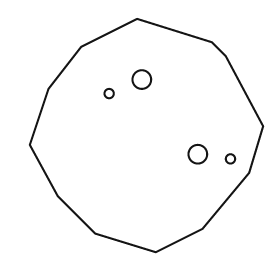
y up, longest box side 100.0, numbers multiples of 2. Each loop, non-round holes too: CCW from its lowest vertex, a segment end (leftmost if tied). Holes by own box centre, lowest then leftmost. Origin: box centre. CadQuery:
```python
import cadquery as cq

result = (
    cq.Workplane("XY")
    .moveTo(4.0, -50.0)
    .lineTo(24.0, -40.0)
    .lineTo(44.0, -16.0)
    .lineTo(50.0, 4.0)
    .lineTo(34.0, 34.0)
    .lineTo(28.0, 40.0)
    .lineTo(-4.0, 50.0)
    .lineTo(-28.0, 38.0)
    .lineTo(-42.0, 20.0)
    .lineTo(-50.0, -4.0)
    .lineTo(-38.0, -26.0)
    .lineTo(-22.0, -42.0)
    .close()
    .moveTo(36.0, -10.0)
    .circle(2.0)
    .moveTo(22.0, -8.0)
    .circle(4.0)
    .moveTo(-16.0, 18.0)
    .circle(2.0)
    .moveTo(-2.0, 24.0)
    .circle(4.0)
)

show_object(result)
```